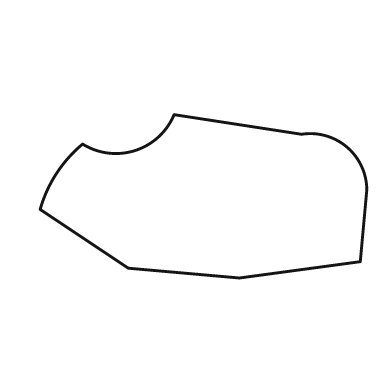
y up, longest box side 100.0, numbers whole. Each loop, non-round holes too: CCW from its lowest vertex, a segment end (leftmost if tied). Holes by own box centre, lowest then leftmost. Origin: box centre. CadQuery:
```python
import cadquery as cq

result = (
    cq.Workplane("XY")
    .moveTo(11.0, -25.0)
    .lineTo(48.0, -20.0)
    .lineTo(50.0, 2.0)
    .threePointArc((44.0, 15.0), (30.0, 19.0))
    .lineTo(-9.0, 25.0)
    .threePointArc((-21.0, 14.0), (-37.0, 16.0))
    .threePointArc((-45.0, 7.0), (-50.0, -4.0))
    .lineTo(-23.0, -22.0)
    .close()
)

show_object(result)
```